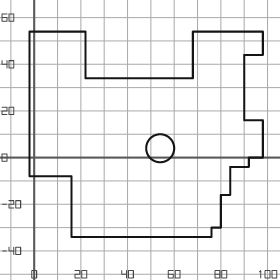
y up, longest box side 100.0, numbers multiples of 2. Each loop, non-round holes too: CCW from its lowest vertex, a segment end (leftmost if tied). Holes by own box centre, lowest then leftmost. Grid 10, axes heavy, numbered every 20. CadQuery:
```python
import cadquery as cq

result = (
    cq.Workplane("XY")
    .moveTo(16.0, -34.0)
    .lineTo(76.0, -34.0)
    .lineTo(76.0, -30.0)
    .lineTo(80.0, -30.0)
    .lineTo(80.0, -16.0)
    .lineTo(84.0, -16.0)
    .lineTo(84.0, -4.0)
    .lineTo(92.0, -4.0)
    .lineTo(92.0, 0.0)
    .lineTo(98.0, 0.0)
    .lineTo(98.0, 16.0)
    .lineTo(90.0, 16.0)
    .lineTo(90.0, 44.0)
    .lineTo(98.0, 44.0)
    .lineTo(98.0, 54.0)
    .lineTo(68.0, 54.0)
    .lineTo(68.0, 34.0)
    .lineTo(22.0, 34.0)
    .lineTo(22.0, 54.0)
    .lineTo(-2.0, 54.0)
    .lineTo(-2.0, -8.0)
    .lineTo(16.0, -8.0)
    .close()
    .moveTo(54.0, 4.0)
    .circle(6.0)
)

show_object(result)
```